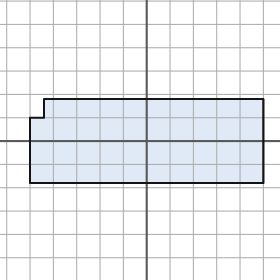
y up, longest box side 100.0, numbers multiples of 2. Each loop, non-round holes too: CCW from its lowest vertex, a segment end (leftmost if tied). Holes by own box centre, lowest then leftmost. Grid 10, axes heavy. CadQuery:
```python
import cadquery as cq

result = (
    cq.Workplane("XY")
    .moveTo(-50.0, -18.0)
    .lineTo(50.0, -18.0)
    .lineTo(50.0, 18.0)
    .lineTo(-44.0, 18.0)
    .lineTo(-44.0, 10.0)
    .lineTo(-50.0, 10.0)
    .close()
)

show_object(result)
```